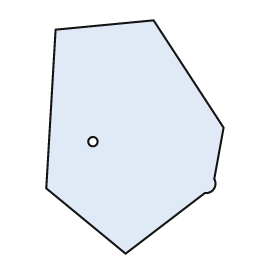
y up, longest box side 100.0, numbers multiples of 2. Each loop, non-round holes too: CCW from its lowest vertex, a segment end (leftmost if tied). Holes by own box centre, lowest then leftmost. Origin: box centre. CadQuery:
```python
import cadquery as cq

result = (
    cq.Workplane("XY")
    .moveTo(-4.0, -50.0)
    .lineTo(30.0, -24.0)
    .threePointArc((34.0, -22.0), (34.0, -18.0))
    .lineTo(38.0, 4.0)
    .lineTo(8.0, 50.0)
    .lineTo(-34.0, 46.0)
    .lineTo(-38.0, -22.0)
    .close()
    .moveTo(-18.0, -2.0)
    .circle(2.0)
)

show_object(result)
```